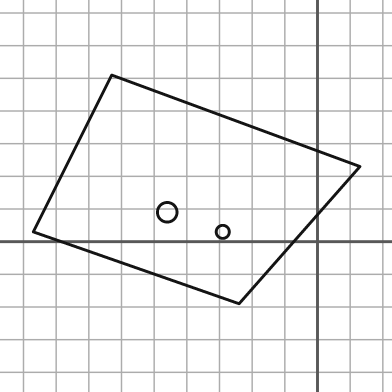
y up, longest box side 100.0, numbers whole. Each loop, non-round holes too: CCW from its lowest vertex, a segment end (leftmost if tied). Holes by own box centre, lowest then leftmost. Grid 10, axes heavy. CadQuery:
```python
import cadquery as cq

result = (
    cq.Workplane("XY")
    .moveTo(-24.0, -19.0)
    .lineTo(13.0, 23.0)
    .lineTo(-63.0, 51.0)
    .lineTo(-87.0, 3.0)
    .close()
    .moveTo(-29.0, 3.0)
    .circle(2.0)
    .moveTo(-46.0, 9.0)
    .circle(3.0)
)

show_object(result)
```